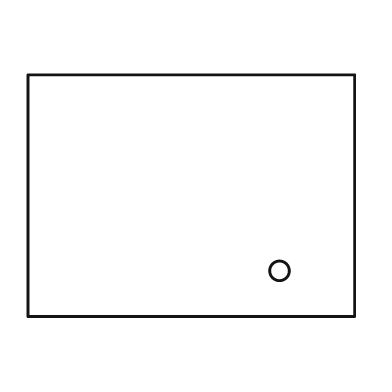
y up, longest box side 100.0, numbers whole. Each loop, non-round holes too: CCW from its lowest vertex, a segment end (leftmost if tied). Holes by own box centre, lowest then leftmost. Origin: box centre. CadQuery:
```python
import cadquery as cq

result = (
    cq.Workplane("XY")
    .moveTo(-50.0, -37.0)
    .lineTo(50.0, -37.0)
    .lineTo(50.0, 37.0)
    .lineTo(-50.0, 37.0)
    .close()
    .moveTo(27.0, -23.0)
    .circle(3.0)
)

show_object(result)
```